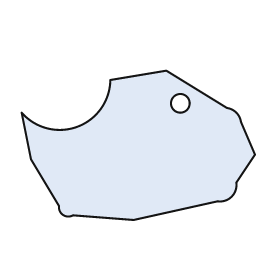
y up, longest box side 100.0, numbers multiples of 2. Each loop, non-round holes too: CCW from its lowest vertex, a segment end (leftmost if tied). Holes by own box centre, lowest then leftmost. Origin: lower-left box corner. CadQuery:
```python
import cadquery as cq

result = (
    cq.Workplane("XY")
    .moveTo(48.0, 0.0)
    .lineTo(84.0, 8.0)
    .threePointArc((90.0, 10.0), (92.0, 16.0))
    .lineTo(100.0, 28.0)
    .lineTo(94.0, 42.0)
    .threePointArc((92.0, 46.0), (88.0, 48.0))
    .lineTo(62.0, 64.0)
    .lineTo(38.0, 60.0)
    .threePointArc((24.0, 40.0), (0.0, 46.0))
    .lineTo(4.0, 26.0)
    .lineTo(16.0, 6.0)
    .threePointArc((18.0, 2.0), (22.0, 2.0))
    .close()
    .moveTo(68.0, 50.0)
    .circle(4.0)
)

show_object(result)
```